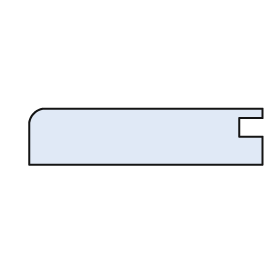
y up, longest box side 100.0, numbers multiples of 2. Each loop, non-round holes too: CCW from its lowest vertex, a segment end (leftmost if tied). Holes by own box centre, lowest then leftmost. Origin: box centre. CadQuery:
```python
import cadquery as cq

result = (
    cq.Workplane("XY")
    .moveTo(-50.0, -12.0)
    .lineTo(50.0, -12.0)
    .lineTo(50.0, 0.0)
    .lineTo(40.0, 0.0)
    .lineTo(40.0, 8.0)
    .lineTo(50.0, 8.0)
    .lineTo(50.0, 12.0)
    .lineTo(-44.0, 12.0)
    .threePointArc((-48.0, 10.0), (-50.0, 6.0))
    .close()
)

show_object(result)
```